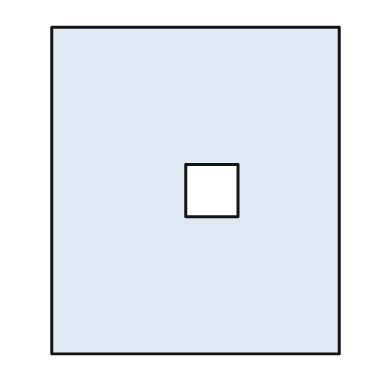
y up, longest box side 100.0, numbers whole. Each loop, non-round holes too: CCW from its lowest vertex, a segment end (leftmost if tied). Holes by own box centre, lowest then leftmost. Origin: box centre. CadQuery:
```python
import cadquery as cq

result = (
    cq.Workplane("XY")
    .moveTo(-44.0, -50.0)
    .lineTo(44.0, -50.0)
    .lineTo(44.0, 50.0)
    .lineTo(-44.0, 50.0)
    .close()
    .moveTo(-3.0, -8.0)
    .lineTo(13.0, -8.0)
    .lineTo(13.0, 8.0)
    .lineTo(-3.0, 8.0)
    .close()
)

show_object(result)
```